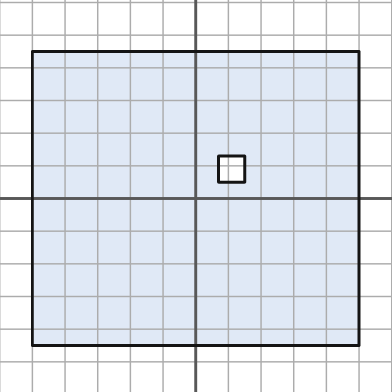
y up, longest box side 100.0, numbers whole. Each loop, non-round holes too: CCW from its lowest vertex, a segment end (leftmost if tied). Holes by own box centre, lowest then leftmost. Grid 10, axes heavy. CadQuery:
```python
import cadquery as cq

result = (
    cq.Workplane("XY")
    .moveTo(-50.0, -45.0)
    .lineTo(50.0, -45.0)
    .lineTo(50.0, 45.0)
    .lineTo(-50.0, 45.0)
    .close()
    .moveTo(7.0, 5.0)
    .lineTo(15.0, 5.0)
    .lineTo(15.0, 13.0)
    .lineTo(7.0, 13.0)
    .close()
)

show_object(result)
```